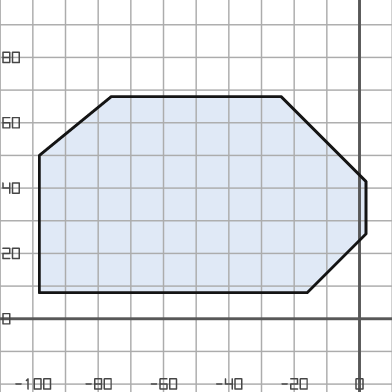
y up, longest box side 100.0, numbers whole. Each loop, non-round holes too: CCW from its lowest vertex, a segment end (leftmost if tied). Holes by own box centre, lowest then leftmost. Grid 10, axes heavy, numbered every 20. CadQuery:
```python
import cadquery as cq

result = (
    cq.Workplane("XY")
    .moveTo(-98.0, 8.0)
    .lineTo(-16.0, 8.0)
    .lineTo(2.0, 26.0)
    .lineTo(2.0, 42.0)
    .lineTo(-24.0, 68.0)
    .lineTo(-76.0, 68.0)
    .lineTo(-98.0, 50.0)
    .close()
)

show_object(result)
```